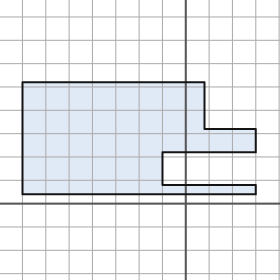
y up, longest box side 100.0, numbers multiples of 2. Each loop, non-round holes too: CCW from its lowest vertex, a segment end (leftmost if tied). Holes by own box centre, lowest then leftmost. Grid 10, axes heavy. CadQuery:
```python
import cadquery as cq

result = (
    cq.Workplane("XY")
    .moveTo(-70.0, 4.0)
    .lineTo(30.0, 4.0)
    .lineTo(30.0, 8.0)
    .lineTo(-10.0, 8.0)
    .lineTo(-10.0, 22.0)
    .lineTo(30.0, 22.0)
    .lineTo(30.0, 32.0)
    .lineTo(8.0, 32.0)
    .lineTo(8.0, 52.0)
    .lineTo(-70.0, 52.0)
    .close()
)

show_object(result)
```